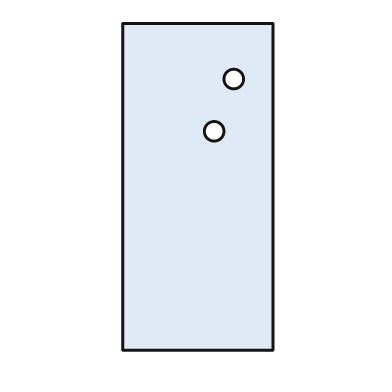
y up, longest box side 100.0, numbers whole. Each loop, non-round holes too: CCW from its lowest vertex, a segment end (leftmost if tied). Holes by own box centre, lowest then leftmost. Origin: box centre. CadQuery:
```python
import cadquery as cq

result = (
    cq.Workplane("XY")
    .moveTo(-23.0, -50.0)
    .lineTo(23.0, -50.0)
    .lineTo(23.0, 50.0)
    .lineTo(-23.0, 50.0)
    .close()
    .moveTo(5.0, 17.0)
    .circle(3.0)
    .moveTo(11.0, 33.0)
    .circle(3.0)
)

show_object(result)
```